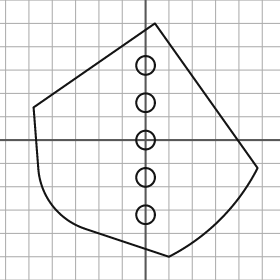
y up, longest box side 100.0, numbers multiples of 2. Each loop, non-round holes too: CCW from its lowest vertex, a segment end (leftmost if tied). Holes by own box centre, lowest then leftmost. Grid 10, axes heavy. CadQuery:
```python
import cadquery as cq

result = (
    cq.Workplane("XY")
    .moveTo(10.0, -50.0)
    .threePointArc((32.0, -34.0), (48.0, -12.0))
    .lineTo(4.0, 50.0)
    .lineTo(-48.0, 14.0)
    .lineTo(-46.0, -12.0)
    .threePointArc((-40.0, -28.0), (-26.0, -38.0))
    .close()
    .moveTo(0.0, -32.0)
    .circle(4.0)
    .moveTo(0.0, -16.0)
    .circle(4.0)
    .moveTo(0.0, 0.0)
    .circle(4.0)
    .moveTo(0.0, 16.0)
    .circle(4.0)
    .moveTo(0.0, 32.0)
    .circle(4.0)
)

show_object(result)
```